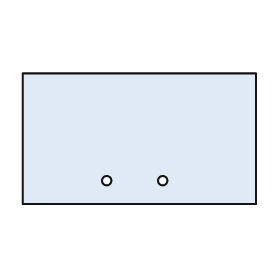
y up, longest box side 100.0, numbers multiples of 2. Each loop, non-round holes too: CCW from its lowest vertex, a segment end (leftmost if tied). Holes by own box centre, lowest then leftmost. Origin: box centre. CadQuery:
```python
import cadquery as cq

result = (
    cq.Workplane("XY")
    .moveTo(-50.0, -28.0)
    .lineTo(50.0, -28.0)
    .lineTo(50.0, 28.0)
    .lineTo(-50.0, 28.0)
    .close()
    .moveTo(-14.0, -18.0)
    .circle(2.0)
    .moveTo(10.0, -18.0)
    .circle(2.0)
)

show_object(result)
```